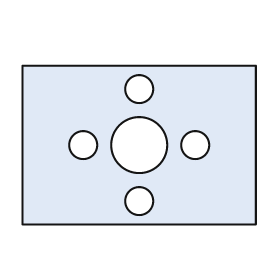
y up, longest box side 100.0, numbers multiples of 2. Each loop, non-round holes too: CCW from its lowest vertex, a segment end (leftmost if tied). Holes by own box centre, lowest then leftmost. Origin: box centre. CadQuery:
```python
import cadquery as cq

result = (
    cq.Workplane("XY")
    .moveTo(-50.0, -34.0)
    .lineTo(50.0, -34.0)
    .lineTo(50.0, 34.0)
    .lineTo(-50.0, 34.0)
    .close()
    .moveTo(0.0, -24.0)
    .circle(6.0)
    .moveTo(-24.0, 0.0)
    .circle(6.0)
    .moveTo(0.0, 0.0)
    .circle(12.0)
    .moveTo(24.0, 0.0)
    .circle(6.0)
    .moveTo(0.0, 24.0)
    .circle(6.0)
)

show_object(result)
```